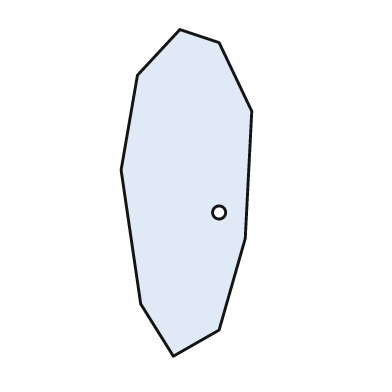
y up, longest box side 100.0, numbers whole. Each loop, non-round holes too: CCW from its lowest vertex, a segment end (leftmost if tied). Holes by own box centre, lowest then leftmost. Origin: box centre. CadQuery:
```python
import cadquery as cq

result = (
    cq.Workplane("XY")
    .moveTo(-4.0, -50.0)
    .lineTo(10.0, -42.0)
    .lineTo(18.0, -14.0)
    .lineTo(20.0, 25.0)
    .lineTo(10.0, 46.0)
    .lineTo(-2.0, 50.0)
    .lineTo(-15.0, 36.0)
    .lineTo(-20.0, 7.0)
    .lineTo(-14.0, -34.0)
    .close()
    .moveTo(10.0, -6.0)
    .circle(2.0)
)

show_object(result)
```